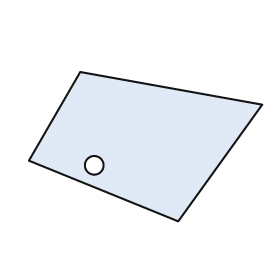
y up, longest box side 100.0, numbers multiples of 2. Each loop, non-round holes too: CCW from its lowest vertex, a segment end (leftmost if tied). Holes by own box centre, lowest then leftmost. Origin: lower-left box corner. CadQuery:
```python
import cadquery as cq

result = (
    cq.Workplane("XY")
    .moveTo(64.0, 0.0)
    .lineTo(100.0, 50.0)
    .lineTo(22.0, 64.0)
    .lineTo(0.0, 26.0)
    .close()
    .moveTo(28.0, 24.0)
    .circle(4.0)
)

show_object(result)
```